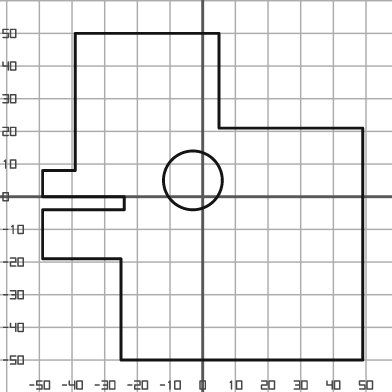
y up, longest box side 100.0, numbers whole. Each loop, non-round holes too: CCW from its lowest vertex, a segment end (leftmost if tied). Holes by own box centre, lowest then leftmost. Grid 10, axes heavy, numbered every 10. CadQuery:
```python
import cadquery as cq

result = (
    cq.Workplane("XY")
    .moveTo(-25.0, -50.0)
    .lineTo(49.0, -50.0)
    .lineTo(49.0, 21.0)
    .lineTo(5.0, 21.0)
    .lineTo(5.0, 50.0)
    .lineTo(-39.0, 50.0)
    .lineTo(-39.0, 8.0)
    .lineTo(-49.0, 8.0)
    .lineTo(-49.0, 0.0)
    .lineTo(-24.0, 0.0)
    .lineTo(-24.0, -4.0)
    .lineTo(-49.0, -4.0)
    .lineTo(-49.0, -19.0)
    .lineTo(-25.0, -19.0)
    .close()
    .moveTo(-3.0, 5.0)
    .circle(9.0)
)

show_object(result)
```